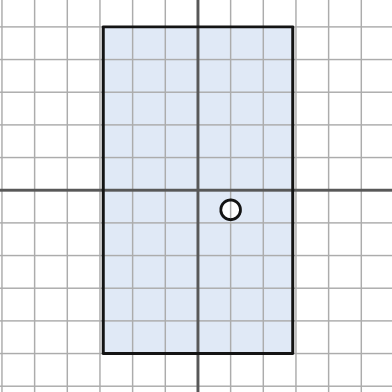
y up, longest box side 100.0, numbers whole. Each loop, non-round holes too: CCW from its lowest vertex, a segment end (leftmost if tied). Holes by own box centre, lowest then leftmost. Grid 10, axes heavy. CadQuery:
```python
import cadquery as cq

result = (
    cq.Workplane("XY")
    .moveTo(-29.0, -50.0)
    .lineTo(29.0, -50.0)
    .lineTo(29.0, 50.0)
    .lineTo(-29.0, 50.0)
    .close()
    .moveTo(10.0, -6.0)
    .circle(3.0)
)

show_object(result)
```